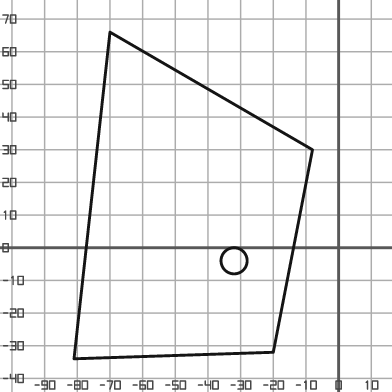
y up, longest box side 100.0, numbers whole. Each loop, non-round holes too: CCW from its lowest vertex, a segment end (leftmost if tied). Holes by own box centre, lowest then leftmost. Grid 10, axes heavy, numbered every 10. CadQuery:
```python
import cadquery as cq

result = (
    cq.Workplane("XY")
    .moveTo(-81.0, -34.0)
    .lineTo(-20.0, -32.0)
    .lineTo(-8.0, 30.0)
    .lineTo(-70.0, 66.0)
    .close()
    .moveTo(-32.0, -4.0)
    .circle(4.0)
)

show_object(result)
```